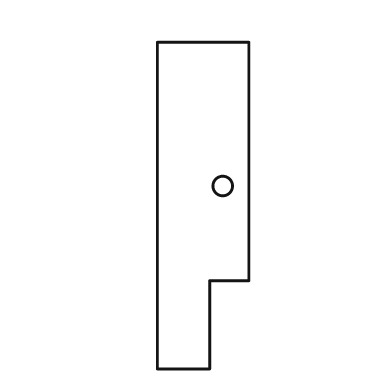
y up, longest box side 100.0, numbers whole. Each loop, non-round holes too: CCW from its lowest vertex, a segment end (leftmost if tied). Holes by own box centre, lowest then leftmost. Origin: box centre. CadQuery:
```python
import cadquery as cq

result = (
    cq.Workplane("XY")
    .moveTo(-14.0, -50.0)
    .lineTo(2.0, -50.0)
    .lineTo(2.0, -23.0)
    .lineTo(14.0, -23.0)
    .lineTo(14.0, 50.0)
    .lineTo(-14.0, 50.0)
    .close()
    .moveTo(6.0, 6.0)
    .circle(3.0)
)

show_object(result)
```